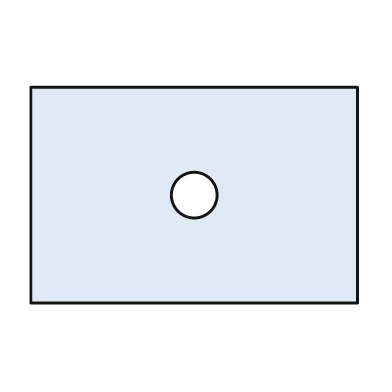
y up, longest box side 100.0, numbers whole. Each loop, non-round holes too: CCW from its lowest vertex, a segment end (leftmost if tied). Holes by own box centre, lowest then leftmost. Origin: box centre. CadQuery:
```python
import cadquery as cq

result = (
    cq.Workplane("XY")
    .moveTo(-50.0, -33.0)
    .lineTo(50.0, -33.0)
    .lineTo(50.0, 33.0)
    .lineTo(-50.0, 33.0)
    .close()
    .moveTo(0.0, 0.0)
    .circle(7.0)
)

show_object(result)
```